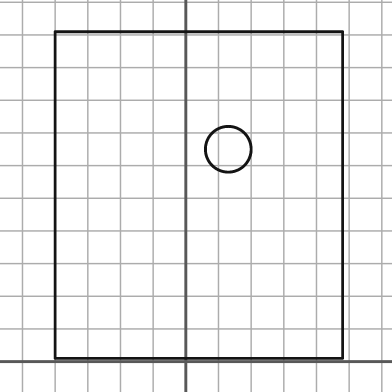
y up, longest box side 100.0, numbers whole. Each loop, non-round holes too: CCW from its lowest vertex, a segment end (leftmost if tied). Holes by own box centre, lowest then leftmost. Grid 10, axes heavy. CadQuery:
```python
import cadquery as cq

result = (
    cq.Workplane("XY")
    .moveTo(-40.0, 1.0)
    .lineTo(48.0, 1.0)
    .lineTo(48.0, 101.0)
    .lineTo(-40.0, 101.0)
    .close()
    .moveTo(13.0, 65.0)
    .circle(7.0)
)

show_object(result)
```